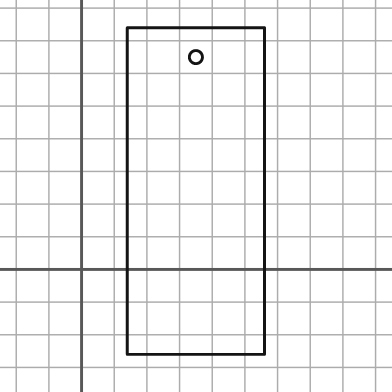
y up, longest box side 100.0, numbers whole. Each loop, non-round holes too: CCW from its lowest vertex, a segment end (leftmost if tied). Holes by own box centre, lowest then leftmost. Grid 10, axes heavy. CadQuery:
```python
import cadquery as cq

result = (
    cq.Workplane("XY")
    .moveTo(14.0, -26.0)
    .lineTo(56.0, -26.0)
    .lineTo(56.0, 74.0)
    .lineTo(14.0, 74.0)
    .close()
    .moveTo(35.0, 65.0)
    .circle(2.0)
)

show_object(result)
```